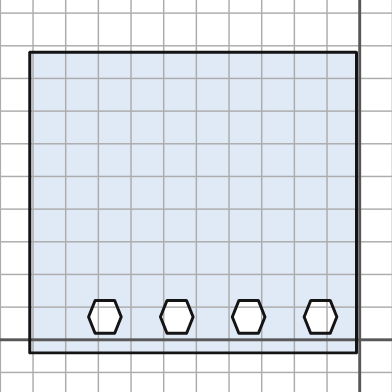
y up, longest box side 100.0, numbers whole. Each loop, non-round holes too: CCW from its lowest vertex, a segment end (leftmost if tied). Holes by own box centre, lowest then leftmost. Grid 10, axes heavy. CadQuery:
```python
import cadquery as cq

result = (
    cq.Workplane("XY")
    .moveTo(-101.0, -4.0)
    .lineTo(-1.0, -4.0)
    .lineTo(-1.0, 88.0)
    .lineTo(-101.0, 88.0)
    .close()
    .moveTo(-81.0, 2.0)
    .lineTo(-75.0, 2.0)
    .lineTo(-73.0, 7.0)
    .lineTo(-75.0, 12.0)
    .lineTo(-81.0, 12.0)
    .lineTo(-83.0, 7.0)
    .close()
    .moveTo(-59.0, 2.0)
    .lineTo(-53.0, 2.0)
    .lineTo(-51.0, 7.0)
    .lineTo(-53.0, 12.0)
    .lineTo(-59.0, 12.0)
    .lineTo(-61.0, 7.0)
    .close()
    .moveTo(-37.0, 2.0)
    .lineTo(-31.0, 2.0)
    .lineTo(-29.0, 7.0)
    .lineTo(-31.0, 12.0)
    .lineTo(-37.0, 12.0)
    .lineTo(-39.0, 7.0)
    .close()
    .moveTo(-15.0, 2.0)
    .lineTo(-9.0, 2.0)
    .lineTo(-7.0, 7.0)
    .lineTo(-9.0, 12.0)
    .lineTo(-15.0, 12.0)
    .lineTo(-17.0, 7.0)
    .close()
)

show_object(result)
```